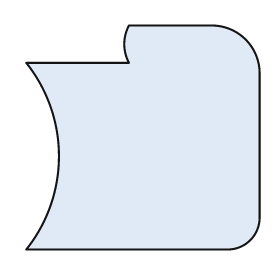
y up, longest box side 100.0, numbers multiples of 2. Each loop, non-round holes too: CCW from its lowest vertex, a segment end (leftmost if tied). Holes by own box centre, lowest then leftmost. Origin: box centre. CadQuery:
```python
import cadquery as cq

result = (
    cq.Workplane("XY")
    .moveTo(-50.0, -48.0)
    .lineTo(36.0, -48.0)
    .threePointArc((46.0, -44.0), (50.0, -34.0))
    .lineTo(50.0, 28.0)
    .threePointArc((44.0, 42.0), (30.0, 48.0))
    .lineTo(-6.0, 48.0)
    .threePointArc((-8.0, 40.0), (-6.0, 32.0))
    .lineTo(-50.0, 32.0)
    .threePointArc((-36.0, -8.0), (-50.0, -48.0))
    .close()
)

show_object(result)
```